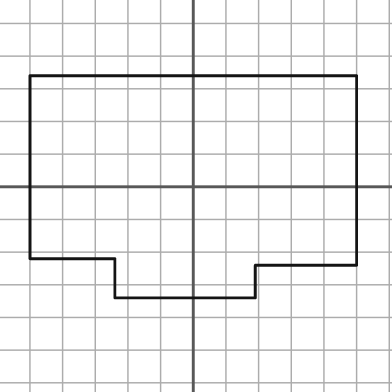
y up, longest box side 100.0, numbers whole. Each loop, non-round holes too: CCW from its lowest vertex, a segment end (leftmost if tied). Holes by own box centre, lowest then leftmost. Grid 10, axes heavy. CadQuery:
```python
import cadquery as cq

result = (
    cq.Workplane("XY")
    .moveTo(-24.0, -34.0)
    .lineTo(19.0, -34.0)
    .lineTo(19.0, -24.0)
    .lineTo(50.0, -24.0)
    .lineTo(50.0, 34.0)
    .lineTo(-50.0, 34.0)
    .lineTo(-50.0, -22.0)
    .lineTo(-24.0, -22.0)
    .close()
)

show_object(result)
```